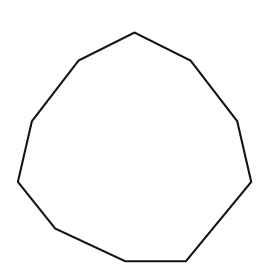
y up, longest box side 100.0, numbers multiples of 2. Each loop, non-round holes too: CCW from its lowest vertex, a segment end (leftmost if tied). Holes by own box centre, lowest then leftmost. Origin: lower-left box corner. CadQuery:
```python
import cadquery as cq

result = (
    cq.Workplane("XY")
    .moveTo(46.0, 0.0)
    .lineTo(72.0, 0.0)
    .lineTo(100.0, 34.0)
    .lineTo(94.0, 60.0)
    .lineTo(74.0, 86.0)
    .lineTo(50.0, 98.0)
    .lineTo(26.0, 86.0)
    .lineTo(6.0, 60.0)
    .lineTo(0.0, 34.0)
    .lineTo(16.0, 14.0)
    .close()
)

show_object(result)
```